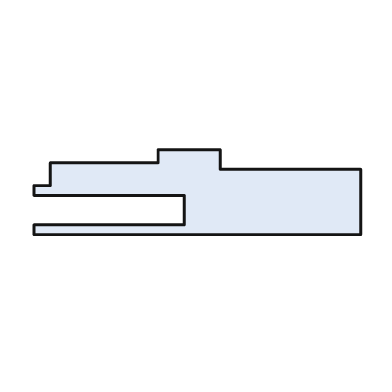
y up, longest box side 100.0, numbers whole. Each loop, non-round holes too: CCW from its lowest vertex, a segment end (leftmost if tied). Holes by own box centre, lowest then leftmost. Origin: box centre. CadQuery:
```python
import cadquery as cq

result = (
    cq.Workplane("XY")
    .moveTo(-50.0, -13.0)
    .lineTo(50.0, -13.0)
    .lineTo(50.0, 7.0)
    .lineTo(7.0, 7.0)
    .lineTo(7.0, 13.0)
    .lineTo(-12.0, 13.0)
    .lineTo(-12.0, 9.0)
    .lineTo(-45.0, 9.0)
    .lineTo(-45.0, 2.0)
    .lineTo(-50.0, 2.0)
    .lineTo(-50.0, -1.0)
    .lineTo(-4.0, -1.0)
    .lineTo(-4.0, -10.0)
    .lineTo(-50.0, -10.0)
    .close()
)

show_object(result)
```